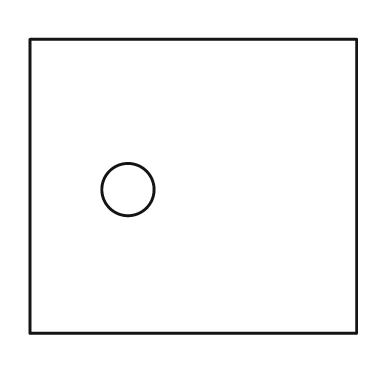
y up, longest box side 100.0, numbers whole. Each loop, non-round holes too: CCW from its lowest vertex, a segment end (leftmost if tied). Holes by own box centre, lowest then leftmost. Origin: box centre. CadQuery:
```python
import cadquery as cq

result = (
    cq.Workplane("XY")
    .moveTo(-50.0, -45.0)
    .lineTo(50.0, -45.0)
    .lineTo(50.0, 45.0)
    .lineTo(-50.0, 45.0)
    .close()
    .moveTo(-20.0, -1.0)
    .circle(8.0)
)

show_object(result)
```